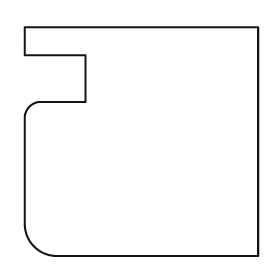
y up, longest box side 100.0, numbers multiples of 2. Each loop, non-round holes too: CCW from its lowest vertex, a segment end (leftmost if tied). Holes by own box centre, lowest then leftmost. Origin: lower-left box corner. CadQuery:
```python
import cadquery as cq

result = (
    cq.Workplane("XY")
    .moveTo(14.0, 0.0)
    .lineTo(100.0, 0.0)
    .lineTo(100.0, 98.0)
    .lineTo(0.0, 98.0)
    .lineTo(0.0, 86.0)
    .lineTo(26.0, 86.0)
    .lineTo(26.0, 66.0)
    .lineTo(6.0, 66.0)
    .threePointArc((2.0, 64.0), (0.0, 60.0))
    .lineTo(0.0, 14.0)
    .threePointArc((4.0, 4.0), (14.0, 0.0))
    .close()
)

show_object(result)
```